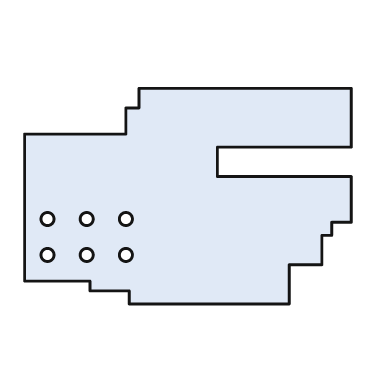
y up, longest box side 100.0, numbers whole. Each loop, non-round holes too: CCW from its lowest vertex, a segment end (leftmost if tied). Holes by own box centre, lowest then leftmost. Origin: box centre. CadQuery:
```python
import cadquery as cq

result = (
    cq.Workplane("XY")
    .moveTo(-18.0, -33.0)
    .lineTo(31.0, -33.0)
    .lineTo(31.0, -21.0)
    .lineTo(41.0, -21.0)
    .lineTo(41.0, -12.0)
    .lineTo(44.0, -12.0)
    .lineTo(44.0, -8.0)
    .lineTo(50.0, -8.0)
    .lineTo(50.0, 6.0)
    .lineTo(9.0, 6.0)
    .lineTo(9.0, 15.0)
    .lineTo(50.0, 15.0)
    .lineTo(50.0, 33.0)
    .lineTo(-15.0, 33.0)
    .lineTo(-15.0, 27.0)
    .lineTo(-19.0, 27.0)
    .lineTo(-19.0, 19.0)
    .lineTo(-50.0, 19.0)
    .lineTo(-50.0, -26.0)
    .lineTo(-30.0, -26.0)
    .lineTo(-30.0, -29.0)
    .lineTo(-18.0, -29.0)
    .close()
    .moveTo(-43.0, -18.0)
    .circle(2.0)
    .moveTo(-31.0, -18.0)
    .circle(2.0)
    .moveTo(-19.0, -18.0)
    .circle(2.0)
    .moveTo(-43.0, -7.0)
    .circle(2.0)
    .moveTo(-31.0, -7.0)
    .circle(2.0)
    .moveTo(-19.0, -7.0)
    .circle(2.0)
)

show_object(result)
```